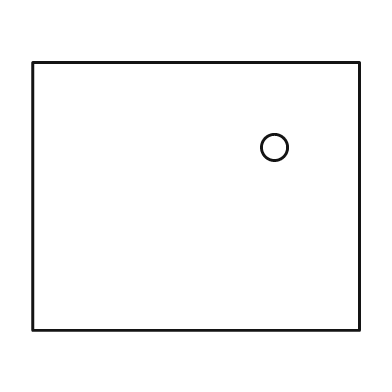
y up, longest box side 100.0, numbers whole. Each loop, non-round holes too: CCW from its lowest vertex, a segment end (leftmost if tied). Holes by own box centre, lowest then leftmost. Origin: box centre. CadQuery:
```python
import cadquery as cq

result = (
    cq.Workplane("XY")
    .moveTo(-50.0, -41.0)
    .lineTo(50.0, -41.0)
    .lineTo(50.0, 41.0)
    .lineTo(-50.0, 41.0)
    .close()
    .moveTo(24.0, 15.0)
    .circle(4.0)
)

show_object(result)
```